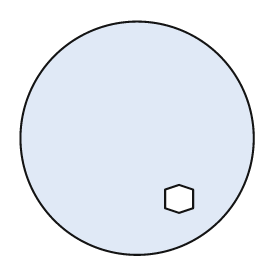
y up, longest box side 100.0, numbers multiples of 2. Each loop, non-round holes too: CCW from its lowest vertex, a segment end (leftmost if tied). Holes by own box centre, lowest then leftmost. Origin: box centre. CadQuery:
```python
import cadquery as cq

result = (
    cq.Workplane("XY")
    .moveTo(0.0, 0.0)
    .circle(50.0)
    .moveTo(18.0, -32.0)
    .lineTo(24.0, -30.0)
    .lineTo(24.0, -22.0)
    .lineTo(18.0, -20.0)
    .lineTo(12.0, -22.0)
    .lineTo(12.0, -30.0)
    .close()
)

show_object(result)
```